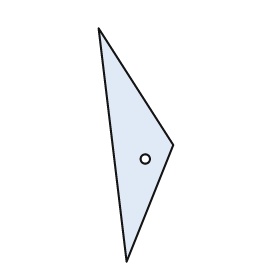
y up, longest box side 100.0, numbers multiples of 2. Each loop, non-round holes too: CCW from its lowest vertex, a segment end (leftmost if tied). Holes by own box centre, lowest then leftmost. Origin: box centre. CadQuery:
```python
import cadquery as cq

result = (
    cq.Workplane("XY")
    .moveTo(-4.0, -50.0)
    .lineTo(16.0, 0.0)
    .lineTo(-16.0, 50.0)
    .close()
    .moveTo(4.0, -6.0)
    .circle(2.0)
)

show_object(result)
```